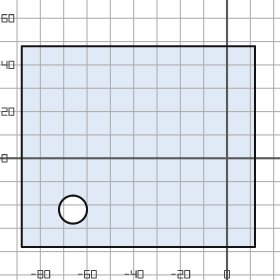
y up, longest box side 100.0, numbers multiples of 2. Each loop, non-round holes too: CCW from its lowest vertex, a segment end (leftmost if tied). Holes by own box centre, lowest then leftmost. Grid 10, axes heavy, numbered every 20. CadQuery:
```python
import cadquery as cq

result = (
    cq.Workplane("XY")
    .moveTo(-88.0, -38.0)
    .lineTo(12.0, -38.0)
    .lineTo(12.0, 48.0)
    .lineTo(-88.0, 48.0)
    .close()
    .moveTo(-66.0, -22.0)
    .circle(6.0)
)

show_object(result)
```